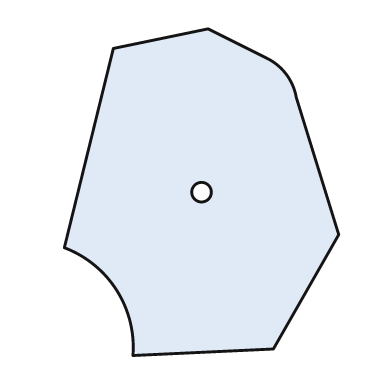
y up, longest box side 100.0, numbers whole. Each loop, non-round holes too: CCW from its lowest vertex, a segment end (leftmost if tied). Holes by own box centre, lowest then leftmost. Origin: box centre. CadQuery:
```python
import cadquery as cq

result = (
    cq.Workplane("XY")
    .moveTo(-21.0, -50.0)
    .lineTo(22.0, -48.0)
    .lineTo(42.0, -13.0)
    .lineTo(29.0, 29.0)
    .threePointArc((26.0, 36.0), (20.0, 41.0))
    .lineTo(2.0, 50.0)
    .lineTo(-27.0, 44.0)
    .lineTo(-42.0, -17.0)
    .threePointArc((-26.0, -30.0), (-21.0, -50.0))
    .close()
    .moveTo(0.0, 0.0)
    .circle(3.0)
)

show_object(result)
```